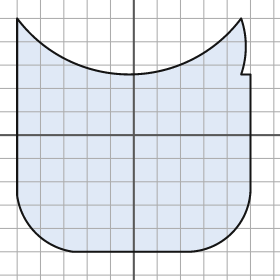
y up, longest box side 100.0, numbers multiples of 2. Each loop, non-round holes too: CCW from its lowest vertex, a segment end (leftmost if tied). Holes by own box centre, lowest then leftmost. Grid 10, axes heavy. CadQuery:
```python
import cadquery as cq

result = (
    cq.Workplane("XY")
    .moveTo(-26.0, -50.0)
    .lineTo(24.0, -50.0)
    .threePointArc((42.0, -42.0), (50.0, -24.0))
    .lineTo(50.0, 26.0)
    .lineTo(46.0, 26.0)
    .threePointArc((48.0, 38.0), (46.0, 50.0))
    .threePointArc((-2.0, 26.0), (-50.0, 50.0))
    .lineTo(-50.0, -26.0)
    .threePointArc((-42.0, -42.0), (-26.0, -50.0))
    .close()
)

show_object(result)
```